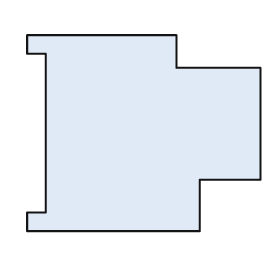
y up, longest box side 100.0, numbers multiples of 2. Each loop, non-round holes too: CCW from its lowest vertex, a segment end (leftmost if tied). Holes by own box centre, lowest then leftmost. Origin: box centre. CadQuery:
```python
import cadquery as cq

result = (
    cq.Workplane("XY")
    .moveTo(-50.0, -42.0)
    .lineTo(24.0, -42.0)
    .lineTo(24.0, -20.0)
    .lineTo(50.0, -20.0)
    .lineTo(50.0, 28.0)
    .lineTo(14.0, 28.0)
    .lineTo(14.0, 42.0)
    .lineTo(-50.0, 42.0)
    .lineTo(-50.0, 34.0)
    .lineTo(-42.0, 34.0)
    .lineTo(-42.0, -34.0)
    .lineTo(-50.0, -34.0)
    .close()
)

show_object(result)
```